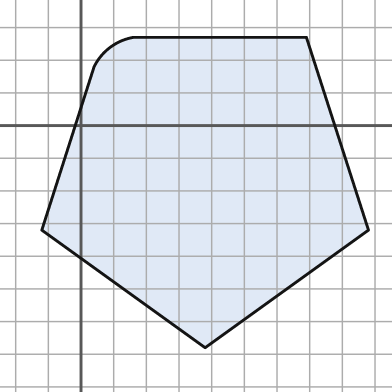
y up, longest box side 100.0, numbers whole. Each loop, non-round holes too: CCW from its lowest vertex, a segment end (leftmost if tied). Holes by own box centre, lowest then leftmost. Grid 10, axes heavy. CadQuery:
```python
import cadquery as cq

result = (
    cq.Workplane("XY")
    .moveTo(38.0, -68.0)
    .lineTo(88.0, -32.0)
    .lineTo(69.0, 27.0)
    .lineTo(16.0, 27.0)
    .threePointArc((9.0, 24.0), (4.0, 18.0))
    .lineTo(-12.0, -32.0)
    .close()
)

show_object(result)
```